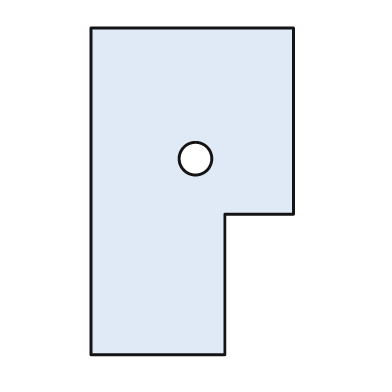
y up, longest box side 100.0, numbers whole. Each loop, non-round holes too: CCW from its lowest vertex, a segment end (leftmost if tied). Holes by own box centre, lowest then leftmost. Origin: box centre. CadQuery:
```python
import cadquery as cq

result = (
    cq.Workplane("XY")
    .moveTo(-31.0, -50.0)
    .lineTo(10.0, -50.0)
    .lineTo(10.0, -7.0)
    .lineTo(31.0, -7.0)
    .lineTo(31.0, 50.0)
    .lineTo(-31.0, 50.0)
    .close()
    .moveTo(1.0, 10.0)
    .circle(5.0)
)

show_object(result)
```